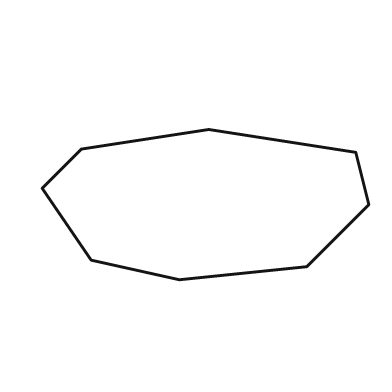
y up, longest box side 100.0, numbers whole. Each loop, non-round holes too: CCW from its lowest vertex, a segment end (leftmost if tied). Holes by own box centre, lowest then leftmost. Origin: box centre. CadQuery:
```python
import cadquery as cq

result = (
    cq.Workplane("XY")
    .moveTo(-8.0, -23.0)
    .lineTo(31.0, -19.0)
    .lineTo(50.0, 0.0)
    .lineTo(46.0, 16.0)
    .lineTo(1.0, 23.0)
    .lineTo(-38.0, 17.0)
    .lineTo(-50.0, 5.0)
    .lineTo(-35.0, -17.0)
    .close()
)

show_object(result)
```